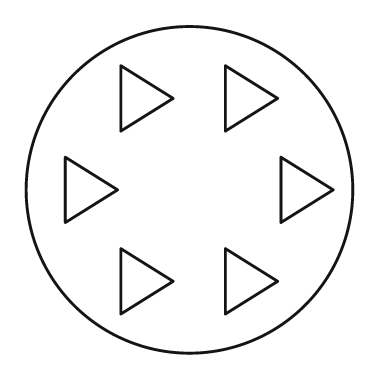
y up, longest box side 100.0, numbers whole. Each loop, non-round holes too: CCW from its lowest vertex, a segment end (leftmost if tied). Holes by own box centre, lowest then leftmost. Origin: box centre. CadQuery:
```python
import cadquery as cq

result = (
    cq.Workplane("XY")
    .moveTo(0.0, 0.0)
    .circle(50.0)
    .moveTo(-21.0, -38.0)
    .lineTo(-5.0, -28.0)
    .lineTo(-21.0, -18.0)
    .close()
    .moveTo(11.0, -38.0)
    .lineTo(27.0, -28.0)
    .lineTo(11.0, -18.0)
    .close()
    .moveTo(-38.0, -10.0)
    .lineTo(-22.0, 0.0)
    .lineTo(-38.0, 10.0)
    .close()
    .moveTo(28.0, -10.0)
    .lineTo(44.0, 0.0)
    .lineTo(28.0, 10.0)
    .close()
    .moveTo(-21.0, 18.0)
    .lineTo(-5.0, 28.0)
    .lineTo(-21.0, 38.0)
    .close()
    .moveTo(11.0, 18.0)
    .lineTo(27.0, 28.0)
    .lineTo(11.0, 38.0)
    .close()
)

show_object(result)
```